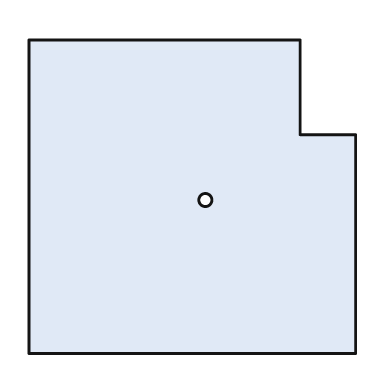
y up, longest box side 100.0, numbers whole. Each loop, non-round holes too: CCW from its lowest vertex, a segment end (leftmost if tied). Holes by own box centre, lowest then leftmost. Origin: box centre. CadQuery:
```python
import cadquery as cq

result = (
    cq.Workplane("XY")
    .moveTo(-50.0, -48.0)
    .lineTo(50.0, -48.0)
    .lineTo(50.0, 19.0)
    .lineTo(33.0, 19.0)
    .lineTo(33.0, 48.0)
    .lineTo(-50.0, 48.0)
    .close()
    .moveTo(4.0, -1.0)
    .circle(2.0)
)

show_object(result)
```